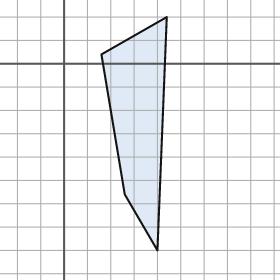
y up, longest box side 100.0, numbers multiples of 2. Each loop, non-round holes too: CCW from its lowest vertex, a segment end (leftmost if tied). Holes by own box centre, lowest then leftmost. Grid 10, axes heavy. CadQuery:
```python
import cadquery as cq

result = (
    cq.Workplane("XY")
    .moveTo(40.0, -80.0)
    .lineTo(44.0, 20.0)
    .lineTo(16.0, 4.0)
    .lineTo(26.0, -56.0)
    .close()
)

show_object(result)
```